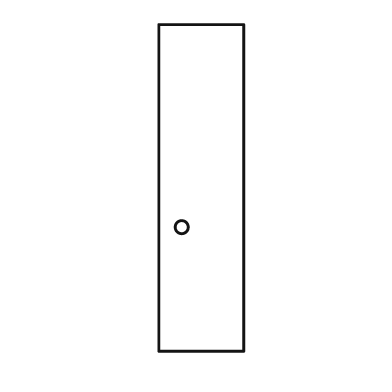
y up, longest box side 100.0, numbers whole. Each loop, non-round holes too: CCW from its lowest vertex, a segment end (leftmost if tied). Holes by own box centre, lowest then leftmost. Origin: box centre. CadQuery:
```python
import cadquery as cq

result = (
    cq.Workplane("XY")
    .moveTo(-13.0, -50.0)
    .lineTo(13.0, -50.0)
    .lineTo(13.0, 50.0)
    .lineTo(-13.0, 50.0)
    .close()
    .moveTo(-6.0, -12.0)
    .circle(2.0)
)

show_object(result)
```